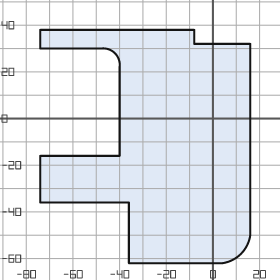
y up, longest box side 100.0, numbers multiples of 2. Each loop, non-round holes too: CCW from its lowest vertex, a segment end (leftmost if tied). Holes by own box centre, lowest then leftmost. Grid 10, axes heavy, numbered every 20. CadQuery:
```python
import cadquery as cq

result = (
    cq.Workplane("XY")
    .moveTo(-36.0, -62.0)
    .lineTo(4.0, -62.0)
    .threePointArc((12.0, -58.0), (16.0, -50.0))
    .lineTo(16.0, 32.0)
    .lineTo(-8.0, 32.0)
    .lineTo(-8.0, 38.0)
    .lineTo(-74.0, 38.0)
    .lineTo(-74.0, 30.0)
    .lineTo(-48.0, 30.0)
    .threePointArc((-42.0, 28.0), (-40.0, 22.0))
    .lineTo(-40.0, -16.0)
    .lineTo(-74.0, -16.0)
    .lineTo(-74.0, -36.0)
    .lineTo(-36.0, -36.0)
    .close()
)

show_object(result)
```